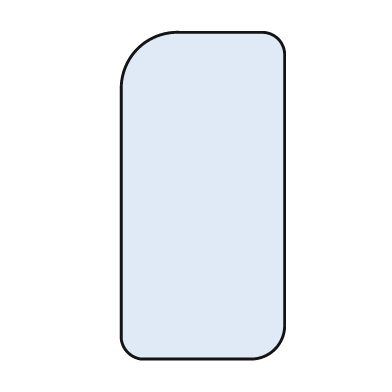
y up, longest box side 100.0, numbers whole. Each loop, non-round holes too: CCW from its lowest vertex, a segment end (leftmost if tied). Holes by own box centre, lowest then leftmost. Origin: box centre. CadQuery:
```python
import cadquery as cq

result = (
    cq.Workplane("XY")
    .moveTo(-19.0, -50.0)
    .lineTo(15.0, -50.0)
    .threePointArc((22.0, -47.0), (25.0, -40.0))
    .lineTo(25.0, 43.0)
    .threePointArc((23.0, 48.0), (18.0, 50.0))
    .lineTo(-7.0, 50.0)
    .threePointArc((-20.0, 45.0), (-25.0, 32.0))
    .lineTo(-25.0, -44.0)
    .threePointArc((-23.0, -48.0), (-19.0, -50.0))
    .close()
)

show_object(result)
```